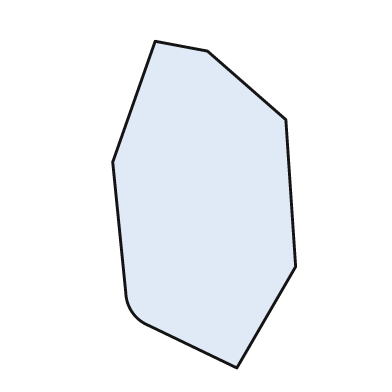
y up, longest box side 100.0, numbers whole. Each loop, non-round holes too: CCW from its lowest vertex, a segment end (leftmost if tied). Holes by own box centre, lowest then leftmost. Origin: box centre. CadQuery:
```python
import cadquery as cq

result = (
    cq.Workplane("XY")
    .moveTo(10.0, -50.0)
    .lineTo(28.0, -19.0)
    .lineTo(25.0, 26.0)
    .lineTo(1.0, 47.0)
    .lineTo(-15.0, 50.0)
    .lineTo(-28.0, 13.0)
    .lineTo(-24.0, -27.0)
    .threePointArc((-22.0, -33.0), (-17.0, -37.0))
    .close()
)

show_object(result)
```